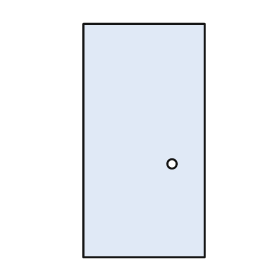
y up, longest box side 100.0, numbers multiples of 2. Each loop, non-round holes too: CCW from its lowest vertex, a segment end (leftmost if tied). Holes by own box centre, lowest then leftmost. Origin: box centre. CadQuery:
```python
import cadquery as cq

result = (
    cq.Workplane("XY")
    .moveTo(-26.0, -50.0)
    .lineTo(26.0, -50.0)
    .lineTo(26.0, 50.0)
    .lineTo(-26.0, 50.0)
    .close()
    .moveTo(12.0, -10.0)
    .circle(2.0)
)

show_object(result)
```